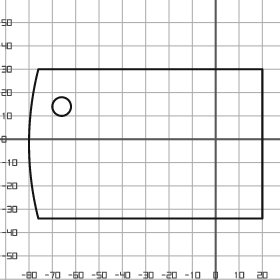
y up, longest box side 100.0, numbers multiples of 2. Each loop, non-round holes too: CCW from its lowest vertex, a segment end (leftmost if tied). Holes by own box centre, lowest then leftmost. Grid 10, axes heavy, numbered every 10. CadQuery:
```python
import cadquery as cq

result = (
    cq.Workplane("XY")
    .moveTo(-76.0, -34.0)
    .lineTo(20.0, -34.0)
    .lineTo(20.0, 30.0)
    .lineTo(-76.0, 30.0)
    .threePointArc((-80.0, -2.0), (-76.0, -34.0))
    .close()
    .moveTo(-66.0, 14.0)
    .circle(4.0)
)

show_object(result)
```